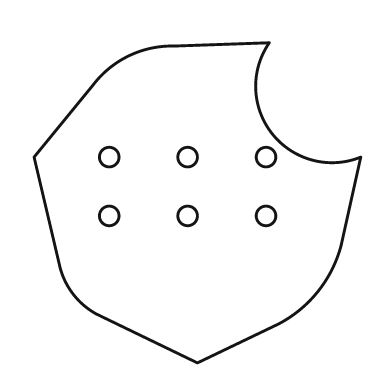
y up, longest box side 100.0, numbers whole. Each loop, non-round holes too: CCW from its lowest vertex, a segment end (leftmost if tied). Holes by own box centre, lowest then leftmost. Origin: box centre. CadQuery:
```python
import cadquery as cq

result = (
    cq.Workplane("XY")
    .moveTo(0.0, -49.0)
    .lineTo(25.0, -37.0)
    .threePointArc((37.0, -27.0), (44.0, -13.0))
    .lineTo(50.0, 14.0)
    .threePointArc((23.0, 21.0), (22.0, 49.0))
    .lineTo(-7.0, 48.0)
    .threePointArc((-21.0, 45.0), (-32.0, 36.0))
    .lineTo(-50.0, 14.0)
    .lineTo(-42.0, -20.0)
    .threePointArc((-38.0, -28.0), (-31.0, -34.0))
    .close()
    .moveTo(-27.0, -4.0)
    .circle(3.0)
    .moveTo(-3.0, -4.0)
    .circle(3.0)
    .moveTo(21.0, -4.0)
    .circle(3.0)
    .moveTo(-27.0, 14.0)
    .circle(3.0)
    .moveTo(-3.0, 14.0)
    .circle(3.0)
    .moveTo(21.0, 14.0)
    .circle(3.0)
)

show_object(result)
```